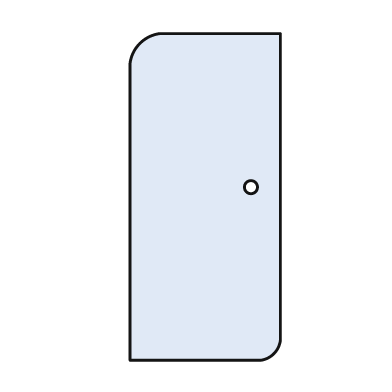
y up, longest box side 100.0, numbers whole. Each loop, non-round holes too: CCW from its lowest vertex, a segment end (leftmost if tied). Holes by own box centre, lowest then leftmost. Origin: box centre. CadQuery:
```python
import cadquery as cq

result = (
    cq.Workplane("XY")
    .moveTo(-23.0, -50.0)
    .lineTo(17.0, -50.0)
    .threePointArc((21.0, -48.0), (23.0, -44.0))
    .lineTo(23.0, 50.0)
    .lineTo(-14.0, 50.0)
    .threePointArc((-20.0, 47.0), (-23.0, 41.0))
    .close()
    .moveTo(14.0, 3.0)
    .circle(2.0)
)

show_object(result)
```